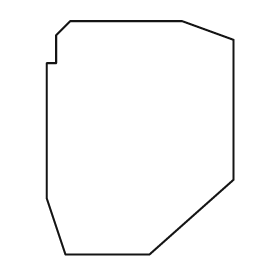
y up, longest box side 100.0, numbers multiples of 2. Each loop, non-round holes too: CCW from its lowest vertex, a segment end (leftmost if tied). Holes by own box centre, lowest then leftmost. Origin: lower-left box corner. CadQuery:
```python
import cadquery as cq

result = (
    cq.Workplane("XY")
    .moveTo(8.0, 0.0)
    .lineTo(44.0, 0.0)
    .lineTo(80.0, 32.0)
    .lineTo(80.0, 92.0)
    .lineTo(58.0, 100.0)
    .lineTo(10.0, 100.0)
    .lineTo(4.0, 94.0)
    .lineTo(4.0, 82.0)
    .lineTo(0.0, 82.0)
    .lineTo(0.0, 24.0)
    .close()
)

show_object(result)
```